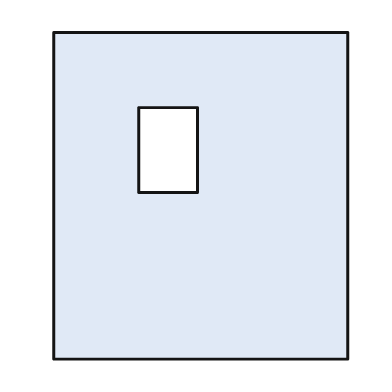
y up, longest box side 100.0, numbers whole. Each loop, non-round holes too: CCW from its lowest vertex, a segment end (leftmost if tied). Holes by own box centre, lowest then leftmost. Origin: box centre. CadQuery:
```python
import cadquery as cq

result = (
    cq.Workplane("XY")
    .moveTo(-45.0, -50.0)
    .lineTo(45.0, -50.0)
    .lineTo(45.0, 50.0)
    .lineTo(-45.0, 50.0)
    .close()
    .moveTo(-19.0, 1.0)
    .lineTo(-1.0, 1.0)
    .lineTo(-1.0, 27.0)
    .lineTo(-19.0, 27.0)
    .close()
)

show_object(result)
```